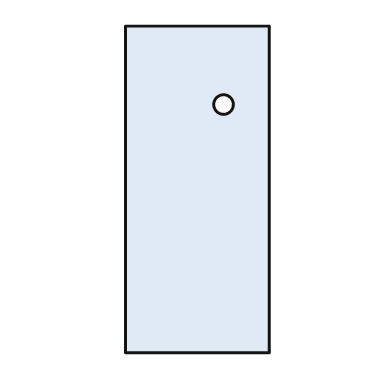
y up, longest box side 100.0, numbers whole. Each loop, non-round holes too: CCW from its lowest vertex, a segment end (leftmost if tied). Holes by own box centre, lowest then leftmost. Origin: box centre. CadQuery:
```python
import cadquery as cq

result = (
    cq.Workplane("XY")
    .moveTo(-22.0, -50.0)
    .lineTo(22.0, -50.0)
    .lineTo(22.0, 50.0)
    .lineTo(-22.0, 50.0)
    .close()
    .moveTo(8.0, 26.0)
    .circle(3.0)
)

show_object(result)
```